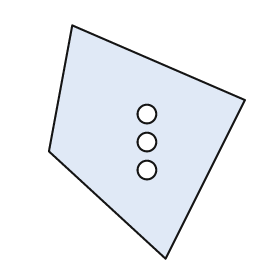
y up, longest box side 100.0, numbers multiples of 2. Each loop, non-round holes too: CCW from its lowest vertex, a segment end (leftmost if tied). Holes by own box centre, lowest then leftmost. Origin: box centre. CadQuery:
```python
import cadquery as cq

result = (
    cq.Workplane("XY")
    .moveTo(8.0, -50.0)
    .lineTo(42.0, 18.0)
    .lineTo(-32.0, 50.0)
    .lineTo(-42.0, -4.0)
    .close()
    .moveTo(0.0, -12.0)
    .circle(4.0)
    .moveTo(0.0, 0.0)
    .circle(4.0)
    .moveTo(0.0, 12.0)
    .circle(4.0)
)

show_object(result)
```